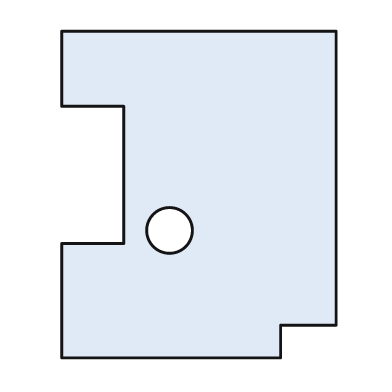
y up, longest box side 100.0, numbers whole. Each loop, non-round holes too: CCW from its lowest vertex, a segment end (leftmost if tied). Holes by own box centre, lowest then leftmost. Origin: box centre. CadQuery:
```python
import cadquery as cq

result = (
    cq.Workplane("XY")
    .moveTo(-42.0, -50.0)
    .lineTo(25.0, -50.0)
    .lineTo(25.0, -40.0)
    .lineTo(42.0, -40.0)
    .lineTo(42.0, 50.0)
    .lineTo(-42.0, 50.0)
    .lineTo(-42.0, 27.0)
    .lineTo(-23.0, 27.0)
    .lineTo(-23.0, -15.0)
    .lineTo(-42.0, -15.0)
    .close()
    .moveTo(-9.0, -11.0)
    .circle(7.0)
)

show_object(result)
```